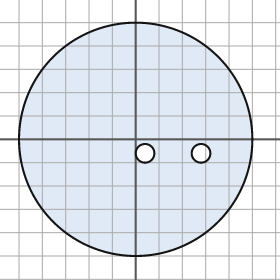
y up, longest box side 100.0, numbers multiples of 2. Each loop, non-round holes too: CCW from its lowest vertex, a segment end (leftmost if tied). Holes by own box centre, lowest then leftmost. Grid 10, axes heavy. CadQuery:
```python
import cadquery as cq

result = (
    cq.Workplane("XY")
    .moveTo(0.0, 0.0)
    .circle(50.0)
    .moveTo(4.0, -6.0)
    .circle(4.0)
    .moveTo(28.0, -6.0)
    .circle(4.0)
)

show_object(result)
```